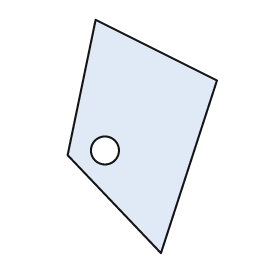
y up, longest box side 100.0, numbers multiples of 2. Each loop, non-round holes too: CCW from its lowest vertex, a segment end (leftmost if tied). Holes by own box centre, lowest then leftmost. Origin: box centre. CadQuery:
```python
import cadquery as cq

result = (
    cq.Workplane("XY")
    .moveTo(8.0, -50.0)
    .lineTo(32.0, 24.0)
    .lineTo(-20.0, 50.0)
    .lineTo(-32.0, -8.0)
    .close()
    .moveTo(-16.0, -6.0)
    .circle(6.0)
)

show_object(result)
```